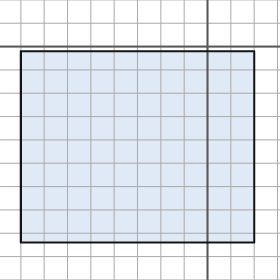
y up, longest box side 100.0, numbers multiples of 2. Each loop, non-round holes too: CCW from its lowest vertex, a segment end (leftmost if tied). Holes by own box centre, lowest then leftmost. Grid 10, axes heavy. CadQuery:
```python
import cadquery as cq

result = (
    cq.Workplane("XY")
    .moveTo(-80.0, -84.0)
    .lineTo(20.0, -84.0)
    .lineTo(20.0, -2.0)
    .lineTo(-80.0, -2.0)
    .close()
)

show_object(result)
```